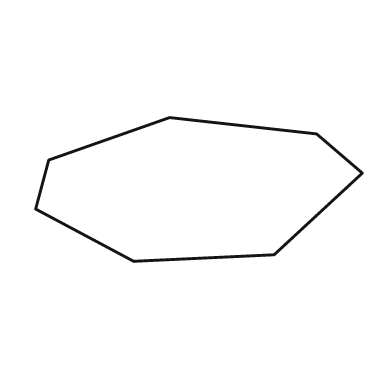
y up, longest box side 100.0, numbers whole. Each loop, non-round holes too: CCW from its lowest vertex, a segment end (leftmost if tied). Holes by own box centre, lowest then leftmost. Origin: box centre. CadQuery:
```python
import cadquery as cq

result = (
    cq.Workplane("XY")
    .moveTo(-20.0, -22.0)
    .lineTo(23.0, -20.0)
    .lineTo(50.0, 5.0)
    .lineTo(36.0, 17.0)
    .lineTo(-9.0, 22.0)
    .lineTo(-46.0, 9.0)
    .lineTo(-50.0, -6.0)
    .close()
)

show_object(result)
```